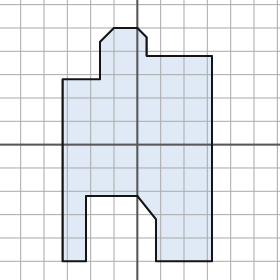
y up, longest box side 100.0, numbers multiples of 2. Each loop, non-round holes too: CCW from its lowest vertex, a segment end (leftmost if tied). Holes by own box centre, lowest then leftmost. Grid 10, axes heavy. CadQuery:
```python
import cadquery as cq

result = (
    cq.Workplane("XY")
    .moveTo(-32.0, -50.0)
    .lineTo(-22.0, -50.0)
    .lineTo(-22.0, -22.0)
    .lineTo(0.0, -22.0)
    .lineTo(8.0, -32.0)
    .lineTo(8.0, -50.0)
    .lineTo(32.0, -50.0)
    .lineTo(32.0, 38.0)
    .lineTo(4.0, 38.0)
    .lineTo(4.0, 46.0)
    .lineTo(0.0, 50.0)
    .lineTo(-10.0, 50.0)
    .lineTo(-16.0, 44.0)
    .lineTo(-16.0, 28.0)
    .lineTo(-32.0, 28.0)
    .close()
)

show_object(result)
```